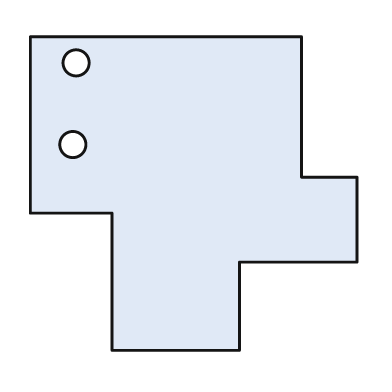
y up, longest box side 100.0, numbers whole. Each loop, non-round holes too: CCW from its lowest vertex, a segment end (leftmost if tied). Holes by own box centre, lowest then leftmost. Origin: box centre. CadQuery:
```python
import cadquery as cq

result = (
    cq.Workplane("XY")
    .moveTo(-25.0, -48.0)
    .lineTo(14.0, -48.0)
    .lineTo(14.0, -21.0)
    .lineTo(50.0, -21.0)
    .lineTo(50.0, 5.0)
    .lineTo(33.0, 5.0)
    .lineTo(33.0, 48.0)
    .lineTo(-50.0, 48.0)
    .lineTo(-50.0, -6.0)
    .lineTo(-25.0, -6.0)
    .close()
    .moveTo(-37.0, 15.0)
    .circle(4.0)
    .moveTo(-36.0, 40.0)
    .circle(4.0)
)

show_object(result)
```